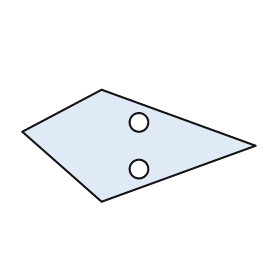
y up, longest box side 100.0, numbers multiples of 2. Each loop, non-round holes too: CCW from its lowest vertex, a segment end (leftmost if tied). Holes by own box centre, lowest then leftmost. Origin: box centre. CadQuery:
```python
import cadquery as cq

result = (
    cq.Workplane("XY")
    .moveTo(-16.0, -24.0)
    .lineTo(50.0, 0.0)
    .lineTo(-16.0, 24.0)
    .lineTo(-50.0, 6.0)
    .close()
    .moveTo(0.0, -10.0)
    .circle(4.0)
    .moveTo(0.0, 10.0)
    .circle(4.0)
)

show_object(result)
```